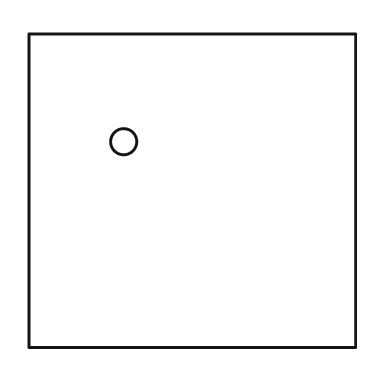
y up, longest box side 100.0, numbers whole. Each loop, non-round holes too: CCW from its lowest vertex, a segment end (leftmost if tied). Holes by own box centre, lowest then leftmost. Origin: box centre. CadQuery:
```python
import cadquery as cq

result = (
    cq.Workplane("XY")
    .moveTo(-50.0, -48.0)
    .lineTo(50.0, -48.0)
    .lineTo(50.0, 48.0)
    .lineTo(-50.0, 48.0)
    .close()
    .moveTo(-21.0, 15.0)
    .circle(4.0)
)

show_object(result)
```